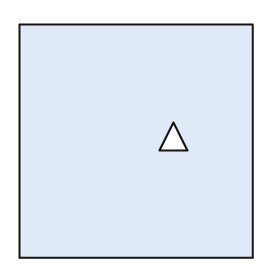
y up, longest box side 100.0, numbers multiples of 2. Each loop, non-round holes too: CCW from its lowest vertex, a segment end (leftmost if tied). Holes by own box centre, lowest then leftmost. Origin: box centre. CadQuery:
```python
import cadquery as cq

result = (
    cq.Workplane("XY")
    .moveTo(-50.0, -50.0)
    .lineTo(50.0, -50.0)
    .lineTo(50.0, 50.0)
    .lineTo(-50.0, 50.0)
    .close()
    .moveTo(10.0, -4.0)
    .lineTo(22.0, -4.0)
    .lineTo(16.0, 8.0)
    .close()
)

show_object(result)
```